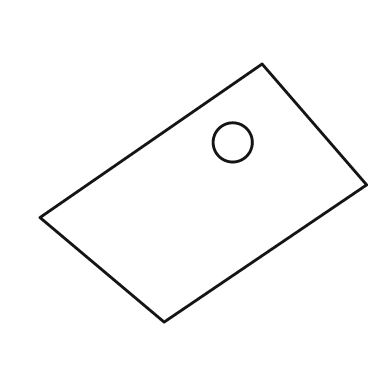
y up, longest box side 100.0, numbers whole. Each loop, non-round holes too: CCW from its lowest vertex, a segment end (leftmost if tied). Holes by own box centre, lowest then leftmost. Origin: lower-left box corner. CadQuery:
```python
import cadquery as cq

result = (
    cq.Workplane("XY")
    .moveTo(38.0, 0.0)
    .lineTo(100.0, 42.0)
    .lineTo(68.0, 79.0)
    .lineTo(0.0, 32.0)
    .close()
    .moveTo(59.0, 55.0)
    .circle(6.0)
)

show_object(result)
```